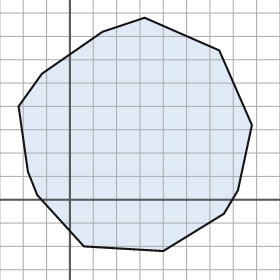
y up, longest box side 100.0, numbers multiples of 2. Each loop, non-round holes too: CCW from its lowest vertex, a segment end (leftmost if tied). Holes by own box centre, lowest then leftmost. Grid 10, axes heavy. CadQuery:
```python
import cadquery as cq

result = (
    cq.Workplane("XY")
    .moveTo(40.0, -22.0)
    .lineTo(66.0, -6.0)
    .lineTo(72.0, 4.0)
    .lineTo(78.0, 32.0)
    .lineTo(64.0, 64.0)
    .lineTo(32.0, 78.0)
    .lineTo(14.0, 72.0)
    .lineTo(-12.0, 54.0)
    .lineTo(-22.0, 40.0)
    .lineTo(-18.0, 12.0)
    .lineTo(-14.0, 2.0)
    .lineTo(6.0, -20.0)
    .close()
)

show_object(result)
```